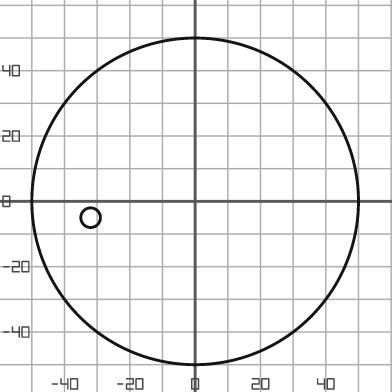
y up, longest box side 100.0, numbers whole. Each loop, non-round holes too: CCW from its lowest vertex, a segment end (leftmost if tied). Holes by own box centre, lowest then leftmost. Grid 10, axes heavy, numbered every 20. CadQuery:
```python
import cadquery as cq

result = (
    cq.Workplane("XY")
    .moveTo(0.0, 0.0)
    .circle(50.0)
    .moveTo(-32.0, -5.0)
    .circle(3.0)
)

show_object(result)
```